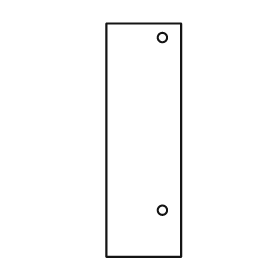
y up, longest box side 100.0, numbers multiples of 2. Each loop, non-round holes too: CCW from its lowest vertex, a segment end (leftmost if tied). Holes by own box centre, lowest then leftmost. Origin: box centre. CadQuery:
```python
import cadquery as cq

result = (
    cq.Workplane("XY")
    .moveTo(-16.0, -50.0)
    .lineTo(16.0, -50.0)
    .lineTo(16.0, 50.0)
    .lineTo(-16.0, 50.0)
    .close()
    .moveTo(8.0, -30.0)
    .circle(2.0)
    .moveTo(8.0, 44.0)
    .circle(2.0)
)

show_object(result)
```